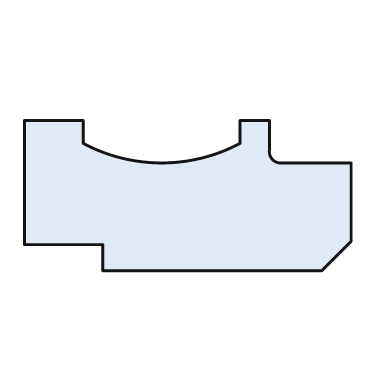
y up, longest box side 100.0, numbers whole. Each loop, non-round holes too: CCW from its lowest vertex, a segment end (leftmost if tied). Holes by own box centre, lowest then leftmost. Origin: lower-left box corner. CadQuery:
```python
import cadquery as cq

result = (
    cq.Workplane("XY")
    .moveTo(24.0, 0.0)
    .lineTo(91.0, 0.0)
    .lineTo(100.0, 9.0)
    .lineTo(100.0, 33.0)
    .lineTo(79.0, 33.0)
    .threePointArc((76.0, 34.0), (75.0, 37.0))
    .lineTo(75.0, 46.0)
    .lineTo(66.0, 46.0)
    .lineTo(66.0, 39.0)
    .threePointArc((42.0, 33.0), (18.0, 39.0))
    .lineTo(18.0, 46.0)
    .lineTo(0.0, 46.0)
    .lineTo(0.0, 8.0)
    .lineTo(24.0, 8.0)
    .close()
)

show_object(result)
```